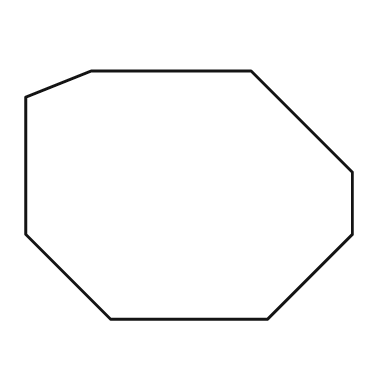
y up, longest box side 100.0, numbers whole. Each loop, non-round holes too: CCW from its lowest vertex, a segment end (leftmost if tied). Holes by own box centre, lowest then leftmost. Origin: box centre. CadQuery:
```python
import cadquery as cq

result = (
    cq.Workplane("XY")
    .moveTo(-24.0, -38.0)
    .lineTo(24.0, -38.0)
    .lineTo(50.0, -12.0)
    .lineTo(50.0, 7.0)
    .lineTo(19.0, 38.0)
    .lineTo(-30.0, 38.0)
    .lineTo(-50.0, 30.0)
    .lineTo(-50.0, -12.0)
    .close()
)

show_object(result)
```